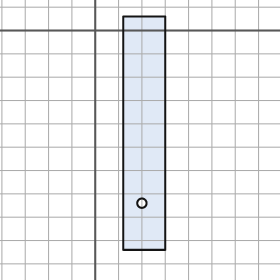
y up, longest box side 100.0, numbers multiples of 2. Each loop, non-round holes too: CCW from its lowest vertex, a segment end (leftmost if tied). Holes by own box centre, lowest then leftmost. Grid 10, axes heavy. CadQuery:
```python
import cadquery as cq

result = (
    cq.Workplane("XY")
    .moveTo(12.0, -94.0)
    .lineTo(30.0, -94.0)
    .lineTo(30.0, 6.0)
    .lineTo(12.0, 6.0)
    .close()
    .moveTo(20.0, -74.0)
    .circle(2.0)
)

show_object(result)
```